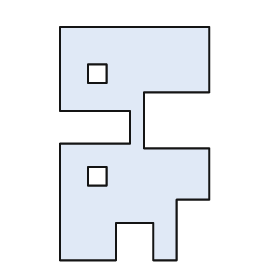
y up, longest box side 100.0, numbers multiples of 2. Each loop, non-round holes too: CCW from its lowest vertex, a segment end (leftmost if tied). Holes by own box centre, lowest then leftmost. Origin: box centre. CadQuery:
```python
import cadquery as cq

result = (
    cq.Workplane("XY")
    .moveTo(-32.0, -50.0)
    .lineTo(-8.0, -50.0)
    .lineTo(-8.0, -34.0)
    .lineTo(8.0, -34.0)
    .lineTo(8.0, -50.0)
    .lineTo(18.0, -50.0)
    .lineTo(18.0, -24.0)
    .lineTo(32.0, -24.0)
    .lineTo(32.0, -2.0)
    .lineTo(4.0, -2.0)
    .lineTo(4.0, 22.0)
    .lineTo(32.0, 22.0)
    .lineTo(32.0, 50.0)
    .lineTo(-32.0, 50.0)
    .lineTo(-32.0, 14.0)
    .lineTo(-2.0, 14.0)
    .lineTo(-2.0, 0.0)
    .lineTo(-32.0, 0.0)
    .close()
    .moveTo(-20.0, -18.0)
    .lineTo(-12.0, -18.0)
    .lineTo(-12.0, -10.0)
    .lineTo(-20.0, -10.0)
    .close()
    .moveTo(-20.0, 26.0)
    .lineTo(-12.0, 26.0)
    .lineTo(-12.0, 34.0)
    .lineTo(-20.0, 34.0)
    .close()
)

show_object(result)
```